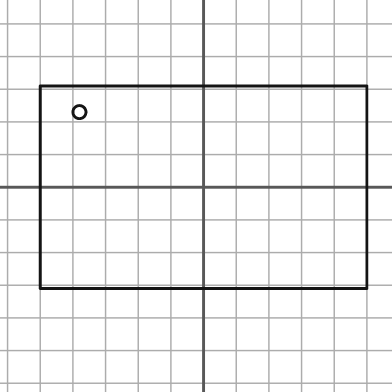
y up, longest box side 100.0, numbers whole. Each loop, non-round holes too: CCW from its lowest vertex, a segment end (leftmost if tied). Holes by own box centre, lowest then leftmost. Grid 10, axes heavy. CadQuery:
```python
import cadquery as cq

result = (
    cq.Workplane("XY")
    .moveTo(-50.0, -31.0)
    .lineTo(50.0, -31.0)
    .lineTo(50.0, 31.0)
    .lineTo(-50.0, 31.0)
    .close()
    .moveTo(-38.0, 23.0)
    .circle(2.0)
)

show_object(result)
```